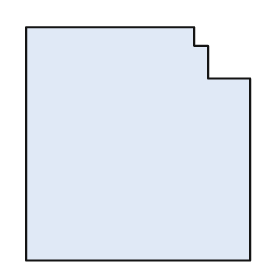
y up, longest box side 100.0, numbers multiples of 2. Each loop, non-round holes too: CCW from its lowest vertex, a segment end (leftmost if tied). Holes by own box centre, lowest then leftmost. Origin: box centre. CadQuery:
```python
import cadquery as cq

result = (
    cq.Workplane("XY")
    .moveTo(-48.0, -50.0)
    .lineTo(48.0, -50.0)
    .lineTo(48.0, 28.0)
    .lineTo(30.0, 28.0)
    .lineTo(30.0, 42.0)
    .lineTo(24.0, 42.0)
    .lineTo(24.0, 50.0)
    .lineTo(-48.0, 50.0)
    .close()
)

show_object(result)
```